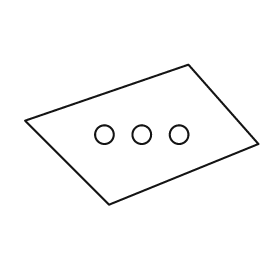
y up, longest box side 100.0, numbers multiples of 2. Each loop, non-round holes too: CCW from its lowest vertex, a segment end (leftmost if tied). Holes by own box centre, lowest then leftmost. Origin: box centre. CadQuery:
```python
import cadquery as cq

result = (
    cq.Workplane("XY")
    .moveTo(-14.0, -30.0)
    .lineTo(50.0, -4.0)
    .lineTo(20.0, 30.0)
    .lineTo(-50.0, 6.0)
    .close()
    .moveTo(-16.0, 0.0)
    .circle(4.0)
    .moveTo(0.0, 0.0)
    .circle(4.0)
    .moveTo(16.0, 0.0)
    .circle(4.0)
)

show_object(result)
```